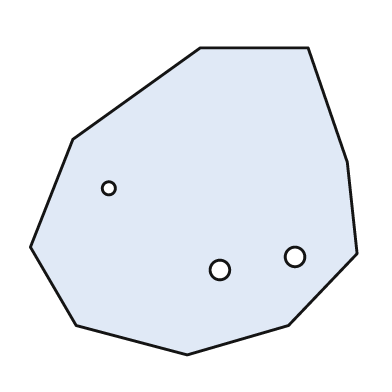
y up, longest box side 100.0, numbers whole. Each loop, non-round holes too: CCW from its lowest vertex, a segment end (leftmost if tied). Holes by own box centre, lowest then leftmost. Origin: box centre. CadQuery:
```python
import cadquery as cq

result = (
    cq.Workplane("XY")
    .moveTo(-2.0, -47.0)
    .lineTo(29.0, -38.0)
    .lineTo(50.0, -16.0)
    .lineTo(47.0, 12.0)
    .lineTo(35.0, 47.0)
    .lineTo(2.0, 47.0)
    .lineTo(-37.0, 19.0)
    .lineTo(-50.0, -14.0)
    .lineTo(-36.0, -38.0)
    .close()
    .moveTo(8.0, -21.0)
    .circle(3.0)
    .moveTo(31.0, -17.0)
    .circle(3.0)
    .moveTo(-26.0, 4.0)
    .circle(2.0)
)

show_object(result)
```